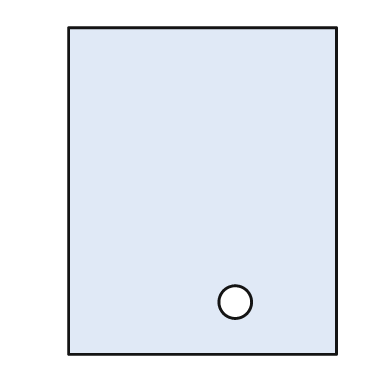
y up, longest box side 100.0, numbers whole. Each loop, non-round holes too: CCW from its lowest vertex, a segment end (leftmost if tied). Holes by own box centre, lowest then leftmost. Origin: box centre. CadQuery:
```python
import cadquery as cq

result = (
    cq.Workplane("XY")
    .moveTo(-41.0, -50.0)
    .lineTo(41.0, -50.0)
    .lineTo(41.0, 50.0)
    .lineTo(-41.0, 50.0)
    .close()
    .moveTo(10.0, -34.0)
    .circle(5.0)
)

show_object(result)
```